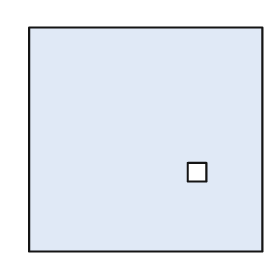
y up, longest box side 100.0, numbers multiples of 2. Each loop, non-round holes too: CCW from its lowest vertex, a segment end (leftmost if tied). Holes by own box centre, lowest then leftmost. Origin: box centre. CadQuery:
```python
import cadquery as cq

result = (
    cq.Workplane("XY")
    .moveTo(-50.0, -48.0)
    .lineTo(50.0, -48.0)
    .lineTo(50.0, 48.0)
    .lineTo(-50.0, 48.0)
    .close()
    .moveTo(18.0, -18.0)
    .lineTo(26.0, -18.0)
    .lineTo(26.0, -10.0)
    .lineTo(18.0, -10.0)
    .close()
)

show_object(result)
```